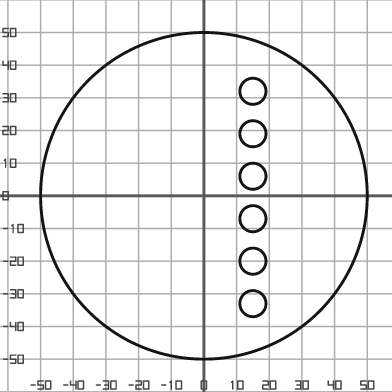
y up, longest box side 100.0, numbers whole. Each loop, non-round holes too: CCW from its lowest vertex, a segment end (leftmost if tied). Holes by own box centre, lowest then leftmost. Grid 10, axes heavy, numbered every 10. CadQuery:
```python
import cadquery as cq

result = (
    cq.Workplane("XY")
    .moveTo(0.0, 0.0)
    .circle(50.0)
    .moveTo(15.0, -33.0)
    .circle(4.0)
    .moveTo(15.0, -20.0)
    .circle(4.0)
    .moveTo(15.0, -7.0)
    .circle(4.0)
    .moveTo(15.0, 6.0)
    .circle(4.0)
    .moveTo(15.0, 19.0)
    .circle(4.0)
    .moveTo(15.0, 32.0)
    .circle(4.0)
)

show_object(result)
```